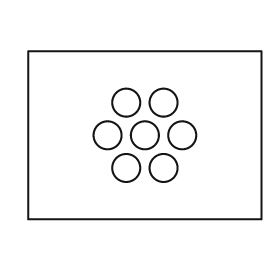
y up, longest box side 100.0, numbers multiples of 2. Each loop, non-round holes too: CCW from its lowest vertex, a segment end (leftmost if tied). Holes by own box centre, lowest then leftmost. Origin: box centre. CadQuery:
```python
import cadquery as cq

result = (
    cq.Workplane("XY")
    .moveTo(-50.0, -36.0)
    .lineTo(50.0, -36.0)
    .lineTo(50.0, 36.0)
    .lineTo(-50.0, 36.0)
    .close()
    .moveTo(-8.0, -14.0)
    .circle(6.0)
    .moveTo(8.0, -14.0)
    .circle(6.0)
    .moveTo(-16.0, 0.0)
    .circle(6.0)
    .moveTo(0.0, 0.0)
    .circle(6.0)
    .moveTo(16.0, 0.0)
    .circle(6.0)
    .moveTo(-8.0, 14.0)
    .circle(6.0)
    .moveTo(8.0, 14.0)
    .circle(6.0)
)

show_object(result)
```